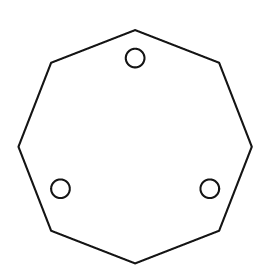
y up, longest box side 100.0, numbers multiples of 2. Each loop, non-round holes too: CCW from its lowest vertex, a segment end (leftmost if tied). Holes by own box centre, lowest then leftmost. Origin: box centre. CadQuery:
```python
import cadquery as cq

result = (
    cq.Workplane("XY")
    .moveTo(0.0, -50.0)
    .lineTo(36.0, -36.0)
    .lineTo(50.0, 0.0)
    .lineTo(36.0, 36.0)
    .lineTo(0.0, 50.0)
    .lineTo(-36.0, 36.0)
    .lineTo(-50.0, 0.0)
    .lineTo(-36.0, -36.0)
    .close()
    .moveTo(-32.0, -18.0)
    .circle(4.0)
    .moveTo(32.0, -18.0)
    .circle(4.0)
    .moveTo(0.0, 38.0)
    .circle(4.0)
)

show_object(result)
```